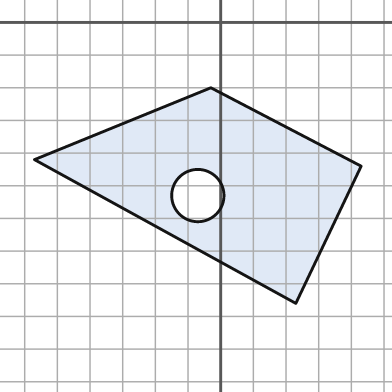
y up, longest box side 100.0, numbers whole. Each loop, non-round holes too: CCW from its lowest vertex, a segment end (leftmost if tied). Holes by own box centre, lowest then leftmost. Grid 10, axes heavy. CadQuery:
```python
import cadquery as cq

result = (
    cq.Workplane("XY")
    .moveTo(23.0, -86.0)
    .lineTo(43.0, -44.0)
    .lineTo(-3.0, -20.0)
    .lineTo(-57.0, -42.0)
    .close()
    .moveTo(-7.0, -53.0)
    .circle(8.0)
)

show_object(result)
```